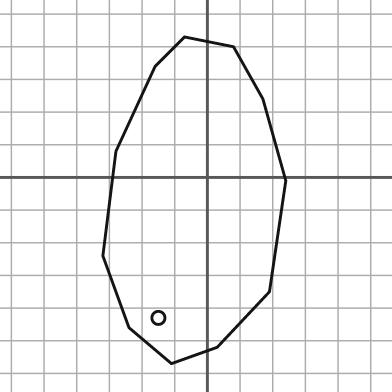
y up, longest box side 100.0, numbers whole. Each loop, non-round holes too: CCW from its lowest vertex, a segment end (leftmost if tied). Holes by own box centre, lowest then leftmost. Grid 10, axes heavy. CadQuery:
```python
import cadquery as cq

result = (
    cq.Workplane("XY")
    .moveTo(-11.0, -57.0)
    .lineTo(3.0, -52.0)
    .lineTo(19.0, -35.0)
    .lineTo(24.0, -1.0)
    .lineTo(17.0, 24.0)
    .lineTo(8.0, 40.0)
    .lineTo(-7.0, 43.0)
    .lineTo(-16.0, 34.0)
    .lineTo(-28.0, 8.0)
    .lineTo(-32.0, -24.0)
    .lineTo(-24.0, -46.0)
    .close()
    .moveTo(-15.0, -43.0)
    .circle(2.0)
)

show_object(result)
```